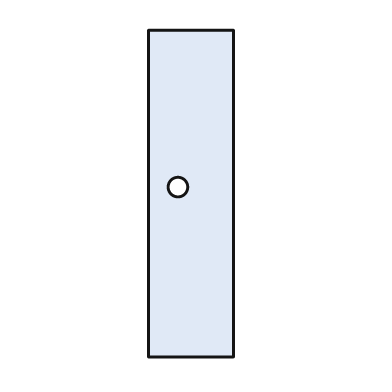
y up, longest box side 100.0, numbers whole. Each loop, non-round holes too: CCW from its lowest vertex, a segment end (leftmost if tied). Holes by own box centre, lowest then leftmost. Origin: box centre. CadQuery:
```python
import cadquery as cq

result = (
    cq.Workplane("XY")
    .moveTo(-13.0, -50.0)
    .lineTo(13.0, -50.0)
    .lineTo(13.0, 50.0)
    .lineTo(-13.0, 50.0)
    .close()
    .moveTo(-4.0, 2.0)
    .circle(3.0)
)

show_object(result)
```